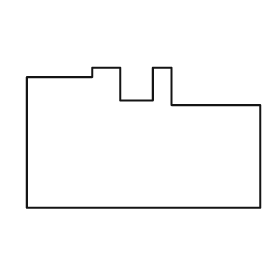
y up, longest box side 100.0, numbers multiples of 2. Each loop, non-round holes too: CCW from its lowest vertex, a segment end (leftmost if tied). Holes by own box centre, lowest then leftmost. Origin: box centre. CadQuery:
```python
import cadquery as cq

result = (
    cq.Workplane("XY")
    .moveTo(-50.0, -30.0)
    .lineTo(50.0, -30.0)
    .lineTo(50.0, 14.0)
    .lineTo(12.0, 14.0)
    .lineTo(12.0, 30.0)
    .lineTo(4.0, 30.0)
    .lineTo(4.0, 16.0)
    .lineTo(-10.0, 16.0)
    .lineTo(-10.0, 30.0)
    .lineTo(-22.0, 30.0)
    .lineTo(-22.0, 26.0)
    .lineTo(-50.0, 26.0)
    .close()
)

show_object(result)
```